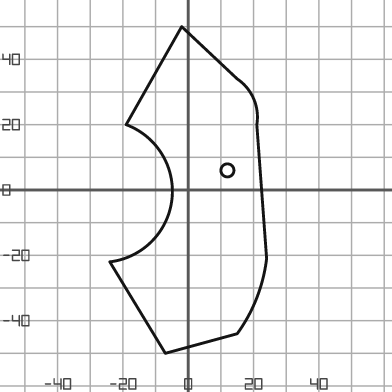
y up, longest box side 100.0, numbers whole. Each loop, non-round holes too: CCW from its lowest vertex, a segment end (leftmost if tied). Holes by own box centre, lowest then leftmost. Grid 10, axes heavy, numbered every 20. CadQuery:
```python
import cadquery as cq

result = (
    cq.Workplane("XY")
    .moveTo(-7.0, -50.0)
    .lineTo(15.0, -44.0)
    .threePointArc((21.0, -33.0), (24.0, -21.0))
    .lineTo(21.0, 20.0)
    .threePointArc((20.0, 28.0), (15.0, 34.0))
    .lineTo(-2.0, 50.0)
    .lineTo(-19.0, 20.0)
    .threePointArc((-5.0, -3.0), (-24.0, -22.0))
    .close()
    .moveTo(12.0, 6.0)
    .circle(2.0)
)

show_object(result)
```